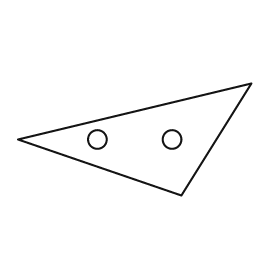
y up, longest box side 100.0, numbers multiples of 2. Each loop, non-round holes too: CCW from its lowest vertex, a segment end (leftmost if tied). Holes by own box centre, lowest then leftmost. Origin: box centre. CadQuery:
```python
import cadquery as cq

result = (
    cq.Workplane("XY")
    .moveTo(20.0, -24.0)
    .lineTo(50.0, 24.0)
    .lineTo(-50.0, 0.0)
    .close()
    .moveTo(-16.0, 0.0)
    .circle(4.0)
    .moveTo(16.0, 0.0)
    .circle(4.0)
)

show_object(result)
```